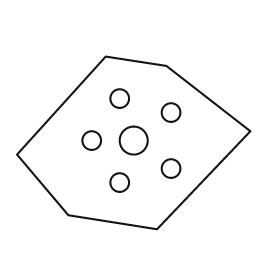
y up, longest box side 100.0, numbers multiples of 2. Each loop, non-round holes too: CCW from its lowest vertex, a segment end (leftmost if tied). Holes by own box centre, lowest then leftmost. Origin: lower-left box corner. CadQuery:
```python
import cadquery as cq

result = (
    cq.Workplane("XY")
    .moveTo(60.0, 0.0)
    .lineTo(100.0, 42.0)
    .lineTo(64.0, 70.0)
    .lineTo(38.0, 74.0)
    .lineTo(0.0, 32.0)
    .lineTo(22.0, 6.0)
    .close()
    .moveTo(44.0, 20.0)
    .circle(4.0)
    .moveTo(66.0, 26.0)
    .circle(4.0)
    .moveTo(32.0, 38.0)
    .circle(4.0)
    .moveTo(50.0, 38.0)
    .circle(6.0)
    .moveTo(66.0, 50.0)
    .circle(4.0)
    .moveTo(44.0, 56.0)
    .circle(4.0)
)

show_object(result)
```